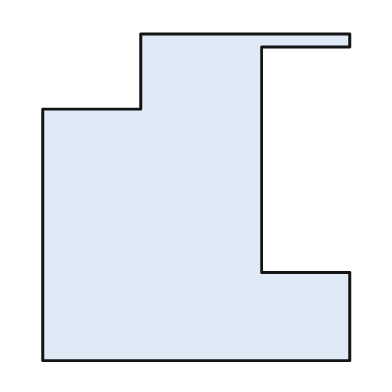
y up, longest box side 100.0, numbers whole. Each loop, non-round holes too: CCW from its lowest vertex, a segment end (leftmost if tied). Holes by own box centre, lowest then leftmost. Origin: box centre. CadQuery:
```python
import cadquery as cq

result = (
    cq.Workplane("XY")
    .moveTo(-47.0, -50.0)
    .lineTo(47.0, -50.0)
    .lineTo(47.0, -23.0)
    .lineTo(20.0, -23.0)
    .lineTo(20.0, 46.0)
    .lineTo(47.0, 46.0)
    .lineTo(47.0, 50.0)
    .lineTo(-17.0, 50.0)
    .lineTo(-17.0, 27.0)
    .lineTo(-47.0, 27.0)
    .close()
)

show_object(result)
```